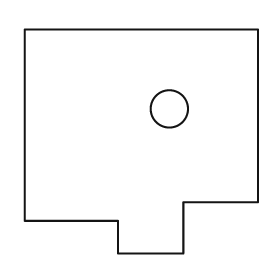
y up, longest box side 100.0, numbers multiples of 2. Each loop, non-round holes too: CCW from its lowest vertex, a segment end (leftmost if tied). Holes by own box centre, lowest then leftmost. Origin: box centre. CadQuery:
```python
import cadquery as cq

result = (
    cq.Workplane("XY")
    .moveTo(-10.0, -48.0)
    .lineTo(18.0, -48.0)
    .lineTo(18.0, -26.0)
    .lineTo(50.0, -26.0)
    .lineTo(50.0, 48.0)
    .lineTo(-50.0, 48.0)
    .lineTo(-50.0, -34.0)
    .lineTo(-10.0, -34.0)
    .close()
    .moveTo(12.0, 14.0)
    .circle(8.0)
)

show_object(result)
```